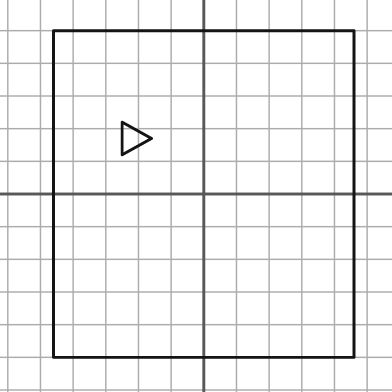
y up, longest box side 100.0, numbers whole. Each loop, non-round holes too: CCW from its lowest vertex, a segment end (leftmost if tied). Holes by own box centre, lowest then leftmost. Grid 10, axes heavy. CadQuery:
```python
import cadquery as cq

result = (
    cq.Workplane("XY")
    .moveTo(-46.0, -50.0)
    .lineTo(46.0, -50.0)
    .lineTo(46.0, 50.0)
    .lineTo(-46.0, 50.0)
    .close()
    .moveTo(-25.0, 12.0)
    .lineTo(-16.0, 17.0)
    .lineTo(-25.0, 22.0)
    .close()
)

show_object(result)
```